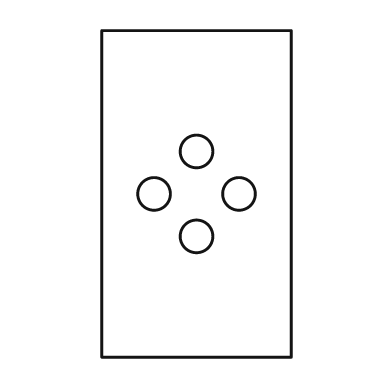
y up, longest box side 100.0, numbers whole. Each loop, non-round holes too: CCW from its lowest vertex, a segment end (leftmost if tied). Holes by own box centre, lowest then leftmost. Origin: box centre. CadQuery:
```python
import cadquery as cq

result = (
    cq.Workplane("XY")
    .moveTo(-29.0, -50.0)
    .lineTo(29.0, -50.0)
    .lineTo(29.0, 50.0)
    .lineTo(-29.0, 50.0)
    .close()
    .moveTo(0.0, -13.0)
    .circle(5.0)
    .moveTo(-13.0, 0.0)
    .circle(5.0)
    .moveTo(13.0, 0.0)
    .circle(5.0)
    .moveTo(0.0, 13.0)
    .circle(5.0)
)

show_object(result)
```